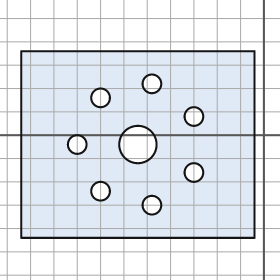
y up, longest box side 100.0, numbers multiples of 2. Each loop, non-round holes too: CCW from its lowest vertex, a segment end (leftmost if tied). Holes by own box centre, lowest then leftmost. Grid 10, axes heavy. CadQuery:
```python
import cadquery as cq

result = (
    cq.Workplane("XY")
    .moveTo(-104.0, -44.0)
    .lineTo(-4.0, -44.0)
    .lineTo(-4.0, 36.0)
    .lineTo(-104.0, 36.0)
    .close()
    .moveTo(-48.0, -30.0)
    .circle(4.0)
    .moveTo(-70.0, -24.0)
    .circle(4.0)
    .moveTo(-30.0, -16.0)
    .circle(4.0)
    .moveTo(-80.0, -4.0)
    .circle(4.0)
    .moveTo(-54.0, -4.0)
    .circle(8.0)
    .moveTo(-30.0, 8.0)
    .circle(4.0)
    .moveTo(-70.0, 16.0)
    .circle(4.0)
    .moveTo(-48.0, 22.0)
    .circle(4.0)
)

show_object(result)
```